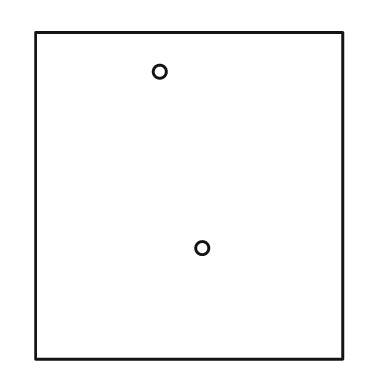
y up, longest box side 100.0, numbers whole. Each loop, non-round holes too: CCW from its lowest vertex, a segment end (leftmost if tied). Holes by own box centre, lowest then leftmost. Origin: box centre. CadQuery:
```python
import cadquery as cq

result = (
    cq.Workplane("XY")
    .moveTo(-47.0, -50.0)
    .lineTo(47.0, -50.0)
    .lineTo(47.0, 50.0)
    .lineTo(-47.0, 50.0)
    .close()
    .moveTo(4.0, -16.0)
    .circle(2.0)
    .moveTo(-9.0, 38.0)
    .circle(2.0)
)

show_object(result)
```